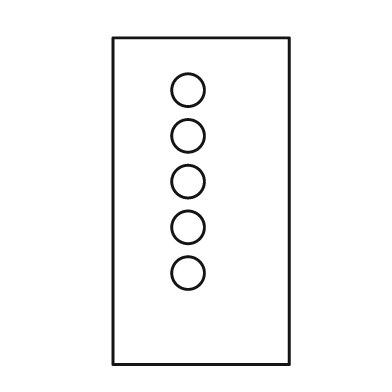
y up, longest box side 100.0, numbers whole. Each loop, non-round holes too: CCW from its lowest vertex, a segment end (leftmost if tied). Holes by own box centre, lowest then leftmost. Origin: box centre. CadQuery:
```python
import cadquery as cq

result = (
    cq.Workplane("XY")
    .moveTo(-27.0, -50.0)
    .lineTo(27.0, -50.0)
    .lineTo(27.0, 50.0)
    .lineTo(-27.0, 50.0)
    .close()
    .moveTo(-4.0, -22.0)
    .circle(5.0)
    .moveTo(-4.0, -8.0)
    .circle(5.0)
    .moveTo(-4.0, 6.0)
    .circle(5.0)
    .moveTo(-4.0, 20.0)
    .circle(5.0)
    .moveTo(-4.0, 34.0)
    .circle(5.0)
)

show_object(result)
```